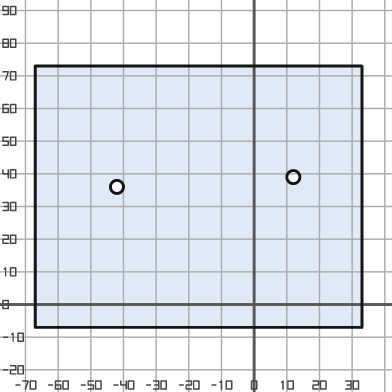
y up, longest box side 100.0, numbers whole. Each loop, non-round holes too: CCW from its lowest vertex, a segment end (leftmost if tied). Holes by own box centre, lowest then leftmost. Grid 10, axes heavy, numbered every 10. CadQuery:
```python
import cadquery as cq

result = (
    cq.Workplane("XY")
    .moveTo(-67.0, -7.0)
    .lineTo(33.0, -7.0)
    .lineTo(33.0, 73.0)
    .lineTo(-67.0, 73.0)
    .close()
    .moveTo(-42.0, 36.0)
    .circle(2.0)
    .moveTo(12.0, 39.0)
    .circle(2.0)
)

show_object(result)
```